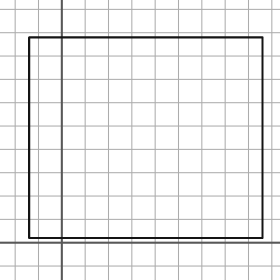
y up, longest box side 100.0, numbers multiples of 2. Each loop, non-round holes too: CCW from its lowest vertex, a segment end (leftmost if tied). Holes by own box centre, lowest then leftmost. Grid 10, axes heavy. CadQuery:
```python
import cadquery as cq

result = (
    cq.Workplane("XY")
    .moveTo(-14.0, 2.0)
    .lineTo(86.0, 2.0)
    .lineTo(86.0, 88.0)
    .lineTo(-14.0, 88.0)
    .close()
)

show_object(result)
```